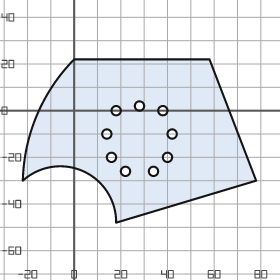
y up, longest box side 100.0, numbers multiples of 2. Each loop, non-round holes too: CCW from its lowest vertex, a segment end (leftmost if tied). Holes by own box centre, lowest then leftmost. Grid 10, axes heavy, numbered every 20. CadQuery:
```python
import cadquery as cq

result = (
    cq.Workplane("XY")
    .moveTo(18.0, -48.0)
    .lineTo(78.0, -30.0)
    .lineTo(58.0, 22.0)
    .lineTo(0.0, 22.0)
    .threePointArc((-16.0, -2.0), (-22.0, -30.0))
    .threePointArc((4.0, -26.0), (18.0, -48.0))
    .close()
    .moveTo(22.0, -26.0)
    .circle(2.0)
    .moveTo(34.0, -26.0)
    .circle(2.0)
    .moveTo(16.0, -20.0)
    .circle(2.0)
    .moveTo(40.0, -20.0)
    .circle(2.0)
    .moveTo(14.0, -10.0)
    .circle(2.0)
    .moveTo(42.0, -10.0)
    .circle(2.0)
    .moveTo(18.0, 0.0)
    .circle(2.0)
    .moveTo(38.0, 0.0)
    .circle(2.0)
    .moveTo(28.0, 2.0)
    .circle(2.0)
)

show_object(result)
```